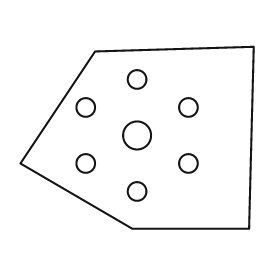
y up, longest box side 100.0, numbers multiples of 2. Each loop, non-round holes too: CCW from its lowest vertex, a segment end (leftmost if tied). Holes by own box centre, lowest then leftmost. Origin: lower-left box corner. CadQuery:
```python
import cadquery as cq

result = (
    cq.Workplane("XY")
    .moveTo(48.0, 0.0)
    .lineTo(98.0, 0.0)
    .lineTo(100.0, 78.0)
    .lineTo(32.0, 76.0)
    .lineTo(0.0, 28.0)
    .close()
    .moveTo(50.0, 16.0)
    .circle(4.0)
    .moveTo(28.0, 28.0)
    .circle(4.0)
    .moveTo(72.0, 28.0)
    .circle(4.0)
    .moveTo(50.0, 40.0)
    .circle(6.0)
    .moveTo(28.0, 52.0)
    .circle(4.0)
    .moveTo(72.0, 52.0)
    .circle(4.0)
    .moveTo(50.0, 64.0)
    .circle(4.0)
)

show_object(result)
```